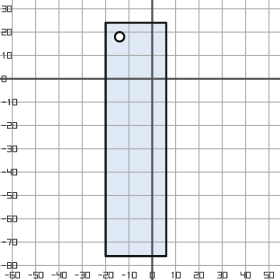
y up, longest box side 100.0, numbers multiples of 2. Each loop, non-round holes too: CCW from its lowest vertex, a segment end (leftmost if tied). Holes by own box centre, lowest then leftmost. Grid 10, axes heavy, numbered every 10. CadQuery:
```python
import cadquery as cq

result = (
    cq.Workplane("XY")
    .moveTo(-20.0, -76.0)
    .lineTo(6.0, -76.0)
    .lineTo(6.0, 24.0)
    .lineTo(-20.0, 24.0)
    .close()
    .moveTo(-14.0, 18.0)
    .circle(2.0)
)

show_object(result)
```